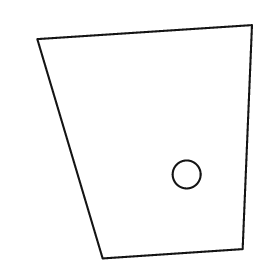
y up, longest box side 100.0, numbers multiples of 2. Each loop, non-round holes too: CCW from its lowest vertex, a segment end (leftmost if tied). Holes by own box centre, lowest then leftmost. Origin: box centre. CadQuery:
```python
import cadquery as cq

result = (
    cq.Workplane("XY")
    .moveTo(-18.0, -50.0)
    .lineTo(42.0, -46.0)
    .lineTo(46.0, 50.0)
    .lineTo(-46.0, 44.0)
    .close()
    .moveTo(18.0, -14.0)
    .circle(6.0)
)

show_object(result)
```